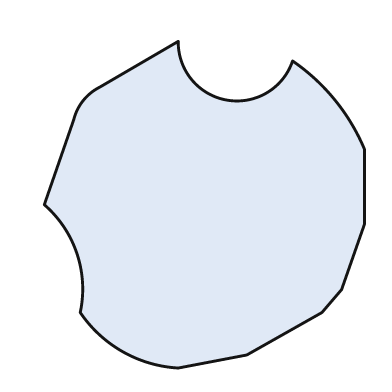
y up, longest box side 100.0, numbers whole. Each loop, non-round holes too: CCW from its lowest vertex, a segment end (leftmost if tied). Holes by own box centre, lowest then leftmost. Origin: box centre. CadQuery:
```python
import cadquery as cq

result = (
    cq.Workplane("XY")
    .moveTo(-8.0, -50.0)
    .lineTo(13.0, -46.0)
    .lineTo(36.0, -33.0)
    .lineTo(42.0, -26.0)
    .lineTo(49.0, -6.0)
    .lineTo(49.0, 17.0)
    .threePointArc((40.0, 32.0), (27.0, 44.0))
    .threePointArc((7.0, 32.0), (-8.0, 50.0))
    .lineTo(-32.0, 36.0)
    .threePointArc((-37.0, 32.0), (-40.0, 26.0))
    .lineTo(-49.0, 0.0)
    .threePointArc((-39.0, -15.0), (-38.0, -33.0))
    .threePointArc((-25.0, -45.0), (-8.0, -50.0))
    .close()
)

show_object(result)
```